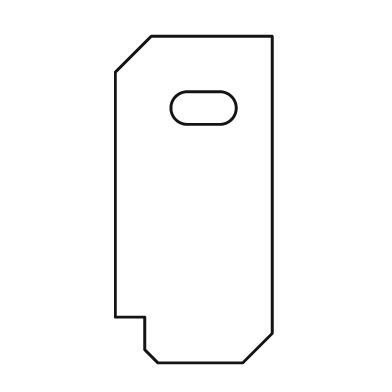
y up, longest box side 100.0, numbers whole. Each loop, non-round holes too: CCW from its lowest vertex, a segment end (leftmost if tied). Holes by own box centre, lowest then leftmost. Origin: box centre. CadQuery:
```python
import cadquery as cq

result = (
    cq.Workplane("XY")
    .moveTo(-11.0, -50.0)
    .lineTo(15.0, -50.0)
    .lineTo(24.0, -41.0)
    .lineTo(24.0, 50.0)
    .lineTo(-13.0, 50.0)
    .lineTo(-24.0, 39.0)
    .lineTo(-24.0, -36.0)
    .lineTo(-15.0, -36.0)
    .lineTo(-15.0, -46.0)
    .close()
    .moveTo(-2.0, 23.0)
    .lineTo(8.0, 23.0)
    .threePointArc((13.0, 28.0), (8.0, 33.0))
    .lineTo(-2.0, 33.0)
    .threePointArc((-7.0, 28.0), (-2.0, 23.0))
    .close()
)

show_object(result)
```